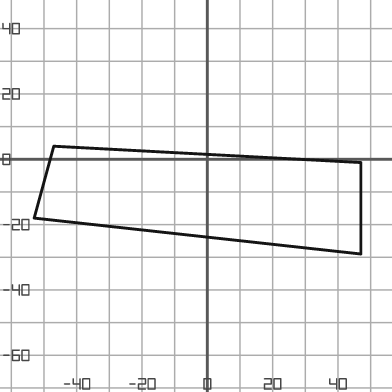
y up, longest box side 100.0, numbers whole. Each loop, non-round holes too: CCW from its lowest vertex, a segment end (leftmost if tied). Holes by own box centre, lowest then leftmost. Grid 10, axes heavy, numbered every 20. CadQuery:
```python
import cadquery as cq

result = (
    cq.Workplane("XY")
    .moveTo(47.0, -29.0)
    .lineTo(47.0, -1.0)
    .lineTo(-47.0, 4.0)
    .lineTo(-53.0, -18.0)
    .close()
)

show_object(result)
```